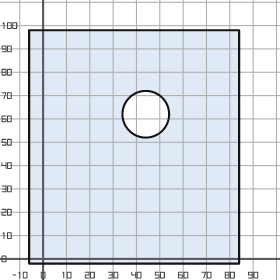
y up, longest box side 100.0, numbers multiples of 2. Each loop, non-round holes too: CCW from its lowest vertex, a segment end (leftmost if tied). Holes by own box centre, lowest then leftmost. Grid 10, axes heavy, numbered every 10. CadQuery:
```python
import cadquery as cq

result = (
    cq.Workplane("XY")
    .moveTo(-6.0, -2.0)
    .lineTo(84.0, -2.0)
    .lineTo(84.0, 98.0)
    .lineTo(-6.0, 98.0)
    .close()
    .moveTo(44.0, 62.0)
    .circle(10.0)
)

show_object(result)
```